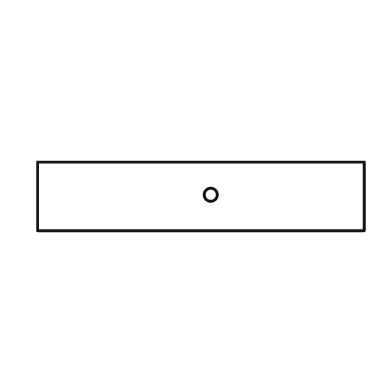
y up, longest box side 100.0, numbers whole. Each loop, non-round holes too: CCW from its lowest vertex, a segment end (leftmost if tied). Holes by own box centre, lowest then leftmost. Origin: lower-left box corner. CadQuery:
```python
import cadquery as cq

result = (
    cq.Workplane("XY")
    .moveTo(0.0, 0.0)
    .lineTo(100.0, 0.0)
    .lineTo(100.0, 21.0)
    .lineTo(0.0, 21.0)
    .close()
    .moveTo(53.0, 11.0)
    .circle(2.0)
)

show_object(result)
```